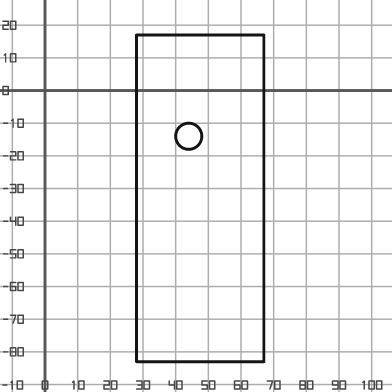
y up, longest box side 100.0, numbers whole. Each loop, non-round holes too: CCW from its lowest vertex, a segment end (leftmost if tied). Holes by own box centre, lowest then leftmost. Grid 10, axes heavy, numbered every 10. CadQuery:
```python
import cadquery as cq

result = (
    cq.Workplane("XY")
    .moveTo(28.0, -83.0)
    .lineTo(67.0, -83.0)
    .lineTo(67.0, 17.0)
    .lineTo(28.0, 17.0)
    .close()
    .moveTo(44.0, -14.0)
    .circle(4.0)
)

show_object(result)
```